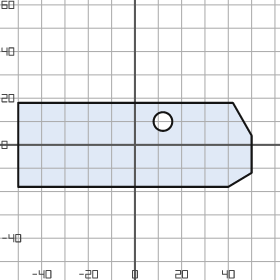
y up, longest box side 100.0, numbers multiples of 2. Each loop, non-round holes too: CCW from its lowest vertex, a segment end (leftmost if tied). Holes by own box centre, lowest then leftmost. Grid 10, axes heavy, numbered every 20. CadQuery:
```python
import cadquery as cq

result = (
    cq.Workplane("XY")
    .moveTo(-50.0, -18.0)
    .lineTo(40.0, -18.0)
    .lineTo(50.0, -12.0)
    .lineTo(50.0, 4.0)
    .lineTo(42.0, 18.0)
    .lineTo(-50.0, 18.0)
    .close()
    .moveTo(12.0, 10.0)
    .circle(4.0)
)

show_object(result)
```